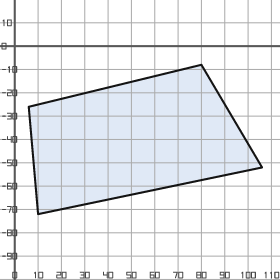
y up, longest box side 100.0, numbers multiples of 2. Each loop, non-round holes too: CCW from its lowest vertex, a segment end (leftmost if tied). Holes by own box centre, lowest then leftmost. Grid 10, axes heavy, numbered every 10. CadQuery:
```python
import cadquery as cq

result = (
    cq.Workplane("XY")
    .moveTo(10.0, -72.0)
    .lineTo(106.0, -52.0)
    .lineTo(80.0, -8.0)
    .lineTo(6.0, -26.0)
    .close()
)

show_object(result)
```